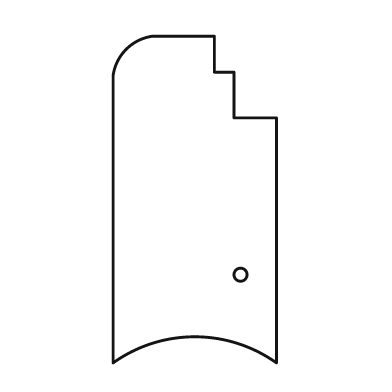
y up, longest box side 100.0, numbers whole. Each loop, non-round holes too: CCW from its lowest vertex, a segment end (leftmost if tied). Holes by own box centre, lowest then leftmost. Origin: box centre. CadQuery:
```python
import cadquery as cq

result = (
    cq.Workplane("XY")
    .moveTo(-25.0, -50.0)
    .threePointArc((0.0, -42.0), (25.0, -50.0))
    .lineTo(25.0, 25.0)
    .lineTo(12.0, 25.0)
    .lineTo(12.0, 39.0)
    .lineTo(6.0, 39.0)
    .lineTo(6.0, 50.0)
    .lineTo(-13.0, 50.0)
    .threePointArc((-21.0, 46.0), (-25.0, 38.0))
    .close()
    .moveTo(14.0, -23.0)
    .circle(2.0)
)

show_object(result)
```